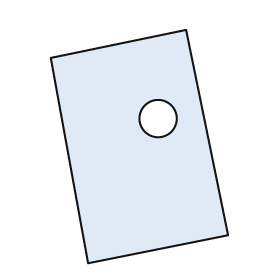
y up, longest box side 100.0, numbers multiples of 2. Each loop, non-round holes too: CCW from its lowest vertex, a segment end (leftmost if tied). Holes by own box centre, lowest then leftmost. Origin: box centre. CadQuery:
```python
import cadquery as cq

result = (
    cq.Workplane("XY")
    .moveTo(-22.0, -50.0)
    .lineTo(38.0, -38.0)
    .lineTo(20.0, 50.0)
    .lineTo(-38.0, 38.0)
    .close()
    .moveTo(8.0, 12.0)
    .circle(8.0)
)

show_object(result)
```